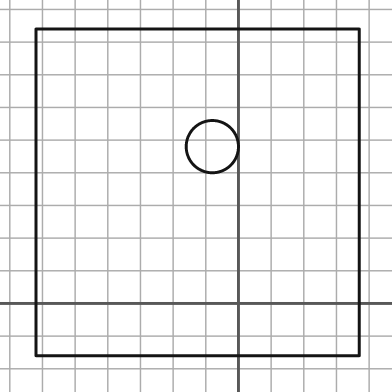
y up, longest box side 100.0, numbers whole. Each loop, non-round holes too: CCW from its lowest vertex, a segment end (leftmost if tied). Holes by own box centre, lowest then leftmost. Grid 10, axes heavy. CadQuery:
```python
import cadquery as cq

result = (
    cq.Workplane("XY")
    .moveTo(-62.0, -16.0)
    .lineTo(37.0, -16.0)
    .lineTo(37.0, 84.0)
    .lineTo(-62.0, 84.0)
    .close()
    .moveTo(-8.0, 48.0)
    .circle(8.0)
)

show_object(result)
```